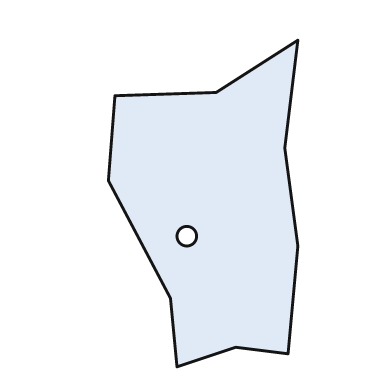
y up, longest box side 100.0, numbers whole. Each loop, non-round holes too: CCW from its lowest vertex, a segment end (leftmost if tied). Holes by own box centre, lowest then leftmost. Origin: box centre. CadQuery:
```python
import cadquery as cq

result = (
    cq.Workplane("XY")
    .moveTo(-8.0, -50.0)
    .lineTo(10.0, -44.0)
    .lineTo(26.0, -46.0)
    .lineTo(29.0, -13.0)
    .lineTo(25.0, 17.0)
    .lineTo(29.0, 50.0)
    .lineTo(4.0, 34.0)
    .lineTo(-27.0, 33.0)
    .lineTo(-29.0, 7.0)
    .lineTo(-10.0, -29.0)
    .close()
    .moveTo(-5.0, -10.0)
    .circle(3.0)
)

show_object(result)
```